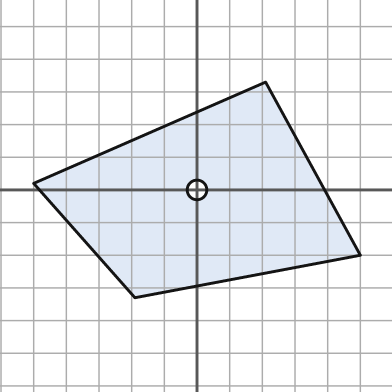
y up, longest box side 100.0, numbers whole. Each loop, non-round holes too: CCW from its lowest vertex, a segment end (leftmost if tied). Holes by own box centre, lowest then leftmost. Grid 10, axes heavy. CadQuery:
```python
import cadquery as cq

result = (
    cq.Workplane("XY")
    .moveTo(-19.0, -33.0)
    .lineTo(50.0, -20.0)
    .lineTo(21.0, 33.0)
    .lineTo(-50.0, 2.0)
    .close()
    .moveTo(0.0, 0.0)
    .circle(3.0)
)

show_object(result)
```